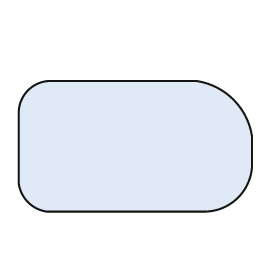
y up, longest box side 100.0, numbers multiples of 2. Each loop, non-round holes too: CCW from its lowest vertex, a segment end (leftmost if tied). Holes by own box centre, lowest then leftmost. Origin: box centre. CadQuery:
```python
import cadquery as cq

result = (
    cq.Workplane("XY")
    .moveTo(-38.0, -28.0)
    .lineTo(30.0, -28.0)
    .threePointArc((44.0, -22.0), (50.0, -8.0))
    .lineTo(50.0, 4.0)
    .threePointArc((42.0, 20.0), (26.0, 28.0))
    .lineTo(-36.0, 28.0)
    .threePointArc((-46.0, 24.0), (-50.0, 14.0))
    .lineTo(-50.0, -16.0)
    .threePointArc((-46.0, -24.0), (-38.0, -28.0))
    .close()
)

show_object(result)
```